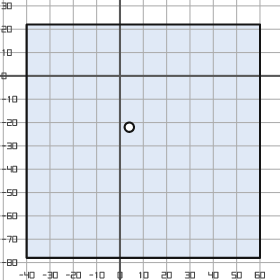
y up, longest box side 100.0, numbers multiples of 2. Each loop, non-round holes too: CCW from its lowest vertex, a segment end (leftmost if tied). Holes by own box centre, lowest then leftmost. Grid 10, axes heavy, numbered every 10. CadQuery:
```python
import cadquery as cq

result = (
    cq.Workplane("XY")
    .moveTo(-40.0, -78.0)
    .lineTo(60.0, -78.0)
    .lineTo(60.0, 22.0)
    .lineTo(-40.0, 22.0)
    .close()
    .moveTo(4.0, -22.0)
    .circle(2.0)
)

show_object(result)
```